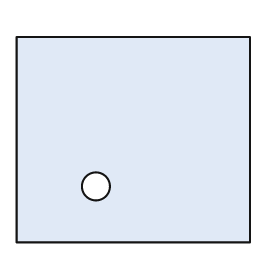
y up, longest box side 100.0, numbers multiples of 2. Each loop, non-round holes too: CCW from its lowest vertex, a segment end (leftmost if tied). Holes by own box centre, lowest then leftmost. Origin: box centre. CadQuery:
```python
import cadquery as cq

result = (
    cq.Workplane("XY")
    .moveTo(-50.0, -44.0)
    .lineTo(50.0, -44.0)
    .lineTo(50.0, 44.0)
    .lineTo(-50.0, 44.0)
    .close()
    .moveTo(-16.0, -20.0)
    .circle(6.0)
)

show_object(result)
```